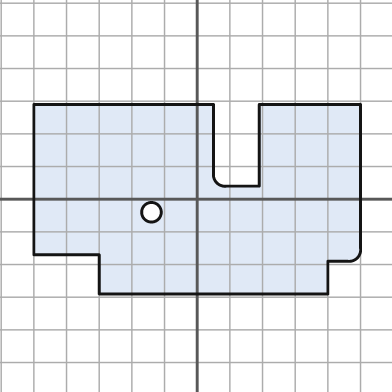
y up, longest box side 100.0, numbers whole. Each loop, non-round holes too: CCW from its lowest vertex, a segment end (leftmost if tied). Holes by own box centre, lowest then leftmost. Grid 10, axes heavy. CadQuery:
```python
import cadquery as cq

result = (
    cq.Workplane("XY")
    .moveTo(-30.0, -29.0)
    .lineTo(40.0, -29.0)
    .lineTo(40.0, -19.0)
    .lineTo(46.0, -19.0)
    .threePointArc((49.0, -18.0), (50.0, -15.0))
    .lineTo(50.0, 29.0)
    .lineTo(19.0, 29.0)
    .lineTo(19.0, 4.0)
    .lineTo(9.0, 4.0)
    .threePointArc((6.0, 5.0), (5.0, 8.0))
    .lineTo(5.0, 29.0)
    .lineTo(-50.0, 29.0)
    .lineTo(-50.0, -17.0)
    .lineTo(-30.0, -17.0)
    .close()
    .moveTo(-14.0, -4.0)
    .circle(3.0)
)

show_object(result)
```